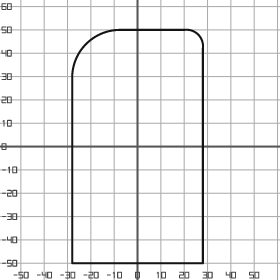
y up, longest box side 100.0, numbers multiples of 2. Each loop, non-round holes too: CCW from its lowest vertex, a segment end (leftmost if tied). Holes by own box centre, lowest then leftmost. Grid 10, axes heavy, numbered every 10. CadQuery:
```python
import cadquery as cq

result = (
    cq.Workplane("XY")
    .moveTo(-28.0, -50.0)
    .lineTo(28.0, -50.0)
    .lineTo(28.0, 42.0)
    .threePointArc((26.0, 48.0), (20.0, 50.0))
    .lineTo(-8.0, 50.0)
    .threePointArc((-22.0, 44.0), (-28.0, 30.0))
    .close()
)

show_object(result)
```